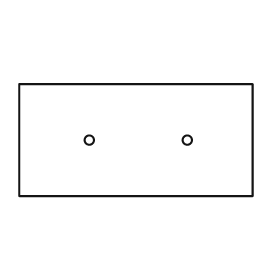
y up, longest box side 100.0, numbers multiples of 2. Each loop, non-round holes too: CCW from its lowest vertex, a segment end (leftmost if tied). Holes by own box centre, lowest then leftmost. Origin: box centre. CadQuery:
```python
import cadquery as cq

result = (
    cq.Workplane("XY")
    .moveTo(-50.0, -24.0)
    .lineTo(50.0, -24.0)
    .lineTo(50.0, 24.0)
    .lineTo(-50.0, 24.0)
    .close()
    .moveTo(-20.0, 0.0)
    .circle(2.0)
    .moveTo(22.0, 0.0)
    .circle(2.0)
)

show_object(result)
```